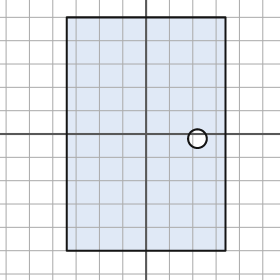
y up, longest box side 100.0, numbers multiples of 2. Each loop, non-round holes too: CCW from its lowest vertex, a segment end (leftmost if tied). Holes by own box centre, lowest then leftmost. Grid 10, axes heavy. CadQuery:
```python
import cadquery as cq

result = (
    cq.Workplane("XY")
    .moveTo(-34.0, -50.0)
    .lineTo(34.0, -50.0)
    .lineTo(34.0, 50.0)
    .lineTo(-34.0, 50.0)
    .close()
    .moveTo(22.0, -2.0)
    .circle(4.0)
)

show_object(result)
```